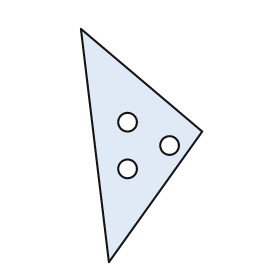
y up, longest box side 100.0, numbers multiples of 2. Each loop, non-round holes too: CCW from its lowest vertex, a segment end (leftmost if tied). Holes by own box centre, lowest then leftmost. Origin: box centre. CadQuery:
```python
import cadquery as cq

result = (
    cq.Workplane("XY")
    .moveTo(-14.0, -50.0)
    .lineTo(26.0, 6.0)
    .lineTo(-26.0, 50.0)
    .close()
    .moveTo(-6.0, -10.0)
    .circle(4.0)
    .moveTo(12.0, 0.0)
    .circle(4.0)
    .moveTo(-6.0, 10.0)
    .circle(4.0)
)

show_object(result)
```